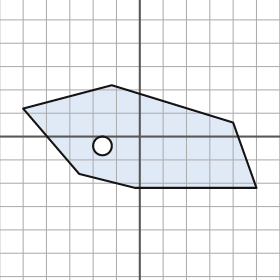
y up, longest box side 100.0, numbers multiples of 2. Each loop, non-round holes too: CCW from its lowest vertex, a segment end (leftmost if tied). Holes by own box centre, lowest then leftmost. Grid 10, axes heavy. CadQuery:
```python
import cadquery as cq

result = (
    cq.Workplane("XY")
    .moveTo(-2.0, -22.0)
    .lineTo(50.0, -22.0)
    .lineTo(40.0, 6.0)
    .lineTo(-12.0, 22.0)
    .lineTo(-50.0, 12.0)
    .lineTo(-26.0, -16.0)
    .close()
    .moveTo(-16.0, -4.0)
    .circle(4.0)
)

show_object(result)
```